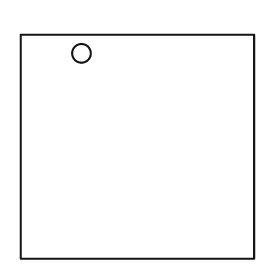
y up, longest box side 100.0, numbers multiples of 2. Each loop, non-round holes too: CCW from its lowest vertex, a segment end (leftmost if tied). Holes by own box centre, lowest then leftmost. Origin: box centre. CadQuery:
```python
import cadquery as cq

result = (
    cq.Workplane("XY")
    .moveTo(-50.0, -48.0)
    .lineTo(50.0, -48.0)
    .lineTo(50.0, 48.0)
    .lineTo(-50.0, 48.0)
    .close()
    .moveTo(-24.0, 40.0)
    .circle(4.0)
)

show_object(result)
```